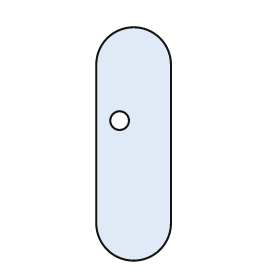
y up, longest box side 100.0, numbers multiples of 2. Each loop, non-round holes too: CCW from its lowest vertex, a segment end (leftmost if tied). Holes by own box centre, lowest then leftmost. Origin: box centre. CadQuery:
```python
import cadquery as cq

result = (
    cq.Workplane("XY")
    .moveTo(-16.0, -34.0)
    .threePointArc((0.0, -50.0), (16.0, -34.0))
    .lineTo(16.0, 34.0)
    .threePointArc((0.0, 50.0), (-16.0, 34.0))
    .close()
    .moveTo(-6.0, 10.0)
    .circle(4.0)
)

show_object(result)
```